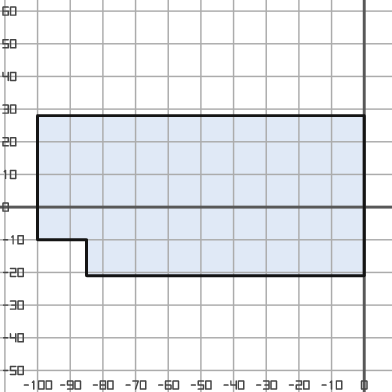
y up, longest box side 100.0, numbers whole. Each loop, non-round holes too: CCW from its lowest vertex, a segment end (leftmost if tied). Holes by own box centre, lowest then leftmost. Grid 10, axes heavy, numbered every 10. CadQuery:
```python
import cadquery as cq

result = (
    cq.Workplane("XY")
    .moveTo(-85.0, -21.0)
    .lineTo(0.0, -21.0)
    .lineTo(0.0, 28.0)
    .lineTo(-100.0, 28.0)
    .lineTo(-100.0, -10.0)
    .lineTo(-85.0, -10.0)
    .close()
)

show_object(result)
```